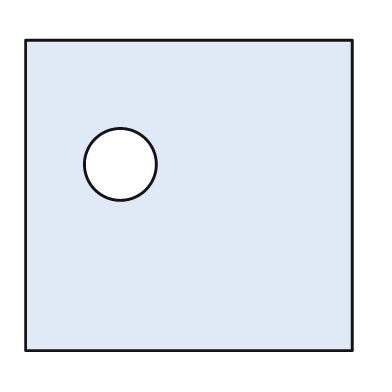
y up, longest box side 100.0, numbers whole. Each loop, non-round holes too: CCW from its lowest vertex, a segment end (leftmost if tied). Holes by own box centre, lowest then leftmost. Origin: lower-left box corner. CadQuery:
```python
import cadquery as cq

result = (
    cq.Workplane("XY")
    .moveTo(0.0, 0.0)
    .lineTo(100.0, 0.0)
    .lineTo(100.0, 95.0)
    .lineTo(0.0, 95.0)
    .close()
    .moveTo(29.0, 57.0)
    .circle(11.0)
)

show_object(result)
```